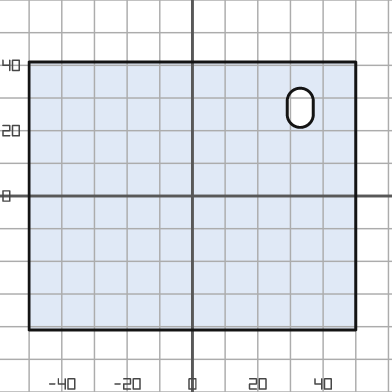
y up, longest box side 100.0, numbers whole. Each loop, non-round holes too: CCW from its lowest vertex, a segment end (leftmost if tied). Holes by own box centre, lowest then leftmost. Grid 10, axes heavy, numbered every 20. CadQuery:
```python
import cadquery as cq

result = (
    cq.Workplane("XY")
    .moveTo(-50.0, -41.0)
    .lineTo(50.0, -41.0)
    .lineTo(50.0, 41.0)
    .lineTo(-50.0, 41.0)
    .close()
    .moveTo(29.0, 25.0)
    .threePointArc((33.0, 21.0), (37.0, 25.0))
    .lineTo(37.0, 29.0)
    .threePointArc((33.0, 33.0), (29.0, 29.0))
    .close()
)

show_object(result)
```